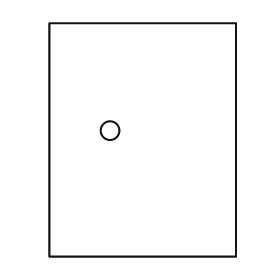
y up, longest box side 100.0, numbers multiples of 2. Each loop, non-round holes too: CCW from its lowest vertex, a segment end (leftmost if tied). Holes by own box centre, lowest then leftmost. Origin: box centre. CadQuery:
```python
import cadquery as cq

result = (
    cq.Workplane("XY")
    .moveTo(-40.0, -50.0)
    .lineTo(40.0, -50.0)
    .lineTo(40.0, 50.0)
    .lineTo(-40.0, 50.0)
    .close()
    .moveTo(-14.0, 4.0)
    .circle(4.0)
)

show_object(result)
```